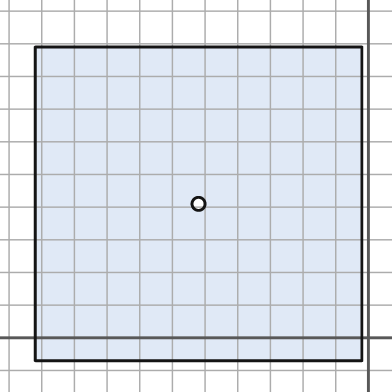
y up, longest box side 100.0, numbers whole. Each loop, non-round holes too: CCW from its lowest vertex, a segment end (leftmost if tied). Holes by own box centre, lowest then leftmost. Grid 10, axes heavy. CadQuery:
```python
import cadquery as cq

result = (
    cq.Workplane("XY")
    .moveTo(-102.0, -7.0)
    .lineTo(-2.0, -7.0)
    .lineTo(-2.0, 89.0)
    .lineTo(-102.0, 89.0)
    .close()
    .moveTo(-52.0, 41.0)
    .circle(2.0)
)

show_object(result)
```